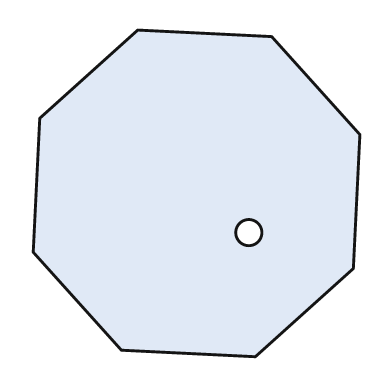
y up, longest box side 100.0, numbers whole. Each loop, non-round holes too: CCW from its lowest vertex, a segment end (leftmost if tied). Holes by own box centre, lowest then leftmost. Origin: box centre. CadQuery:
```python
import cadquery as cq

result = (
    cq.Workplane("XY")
    .moveTo(18.0, -50.0)
    .lineTo(48.0, -23.0)
    .lineTo(50.0, 18.0)
    .lineTo(23.0, 48.0)
    .lineTo(-18.0, 50.0)
    .lineTo(-48.0, 23.0)
    .lineTo(-50.0, -18.0)
    .lineTo(-23.0, -48.0)
    .close()
    .moveTo(16.0, -12.0)
    .circle(4.0)
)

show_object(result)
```